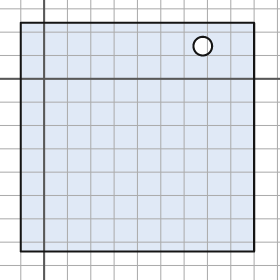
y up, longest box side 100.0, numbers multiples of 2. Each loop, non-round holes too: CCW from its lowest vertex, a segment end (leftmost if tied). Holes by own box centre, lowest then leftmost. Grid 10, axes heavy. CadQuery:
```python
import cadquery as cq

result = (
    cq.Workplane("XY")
    .moveTo(-10.0, -74.0)
    .lineTo(90.0, -74.0)
    .lineTo(90.0, 24.0)
    .lineTo(-10.0, 24.0)
    .close()
    .moveTo(68.0, 14.0)
    .circle(4.0)
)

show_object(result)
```